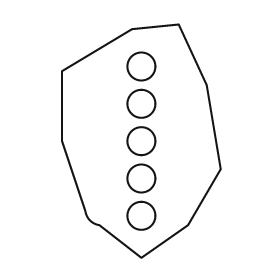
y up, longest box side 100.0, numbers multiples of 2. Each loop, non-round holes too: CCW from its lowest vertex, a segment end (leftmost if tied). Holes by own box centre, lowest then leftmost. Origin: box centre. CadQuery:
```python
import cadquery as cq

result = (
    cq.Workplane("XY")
    .moveTo(0.0, -50.0)
    .lineTo(20.0, -36.0)
    .lineTo(34.0, -12.0)
    .lineTo(28.0, 24.0)
    .lineTo(16.0, 50.0)
    .lineTo(-4.0, 48.0)
    .lineTo(-34.0, 30.0)
    .lineTo(-34.0, 0.0)
    .lineTo(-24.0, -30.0)
    .threePointArc((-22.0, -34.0), (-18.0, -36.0))
    .close()
    .moveTo(0.0, -32.0)
    .circle(6.0)
    .moveTo(0.0, -16.0)
    .circle(6.0)
    .moveTo(0.0, 0.0)
    .circle(6.0)
    .moveTo(0.0, 16.0)
    .circle(6.0)
    .moveTo(0.0, 32.0)
    .circle(6.0)
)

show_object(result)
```